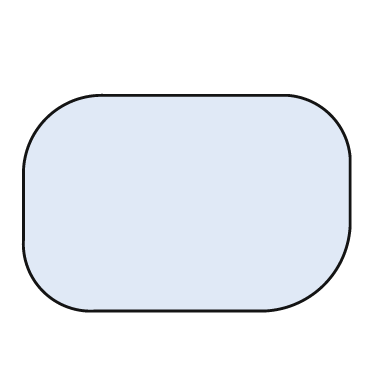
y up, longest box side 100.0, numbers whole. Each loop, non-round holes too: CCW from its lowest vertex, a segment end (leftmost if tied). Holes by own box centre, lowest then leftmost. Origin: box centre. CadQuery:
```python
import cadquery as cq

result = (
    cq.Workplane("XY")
    .moveTo(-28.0, -33.0)
    .lineTo(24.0, -33.0)
    .threePointArc((42.0, -25.0), (50.0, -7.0))
    .lineTo(50.0, 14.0)
    .threePointArc((44.0, 27.0), (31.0, 33.0))
    .lineTo(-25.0, 33.0)
    .threePointArc((-43.0, 26.0), (-50.0, 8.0))
    .lineTo(-50.0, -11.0)
    .threePointArc((-44.0, -27.0), (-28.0, -33.0))
    .close()
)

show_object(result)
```